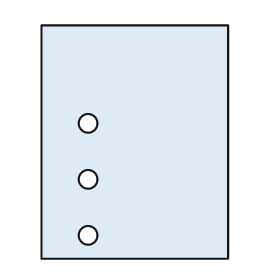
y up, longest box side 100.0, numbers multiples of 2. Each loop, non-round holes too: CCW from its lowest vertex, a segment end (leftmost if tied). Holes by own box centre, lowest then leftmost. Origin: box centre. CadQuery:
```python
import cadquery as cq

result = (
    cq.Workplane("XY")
    .moveTo(-40.0, -50.0)
    .lineTo(40.0, -50.0)
    .lineTo(40.0, 50.0)
    .lineTo(-40.0, 50.0)
    .close()
    .moveTo(-20.0, -40.0)
    .circle(4.0)
    .moveTo(-20.0, -16.0)
    .circle(4.0)
    .moveTo(-20.0, 8.0)
    .circle(4.0)
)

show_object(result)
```